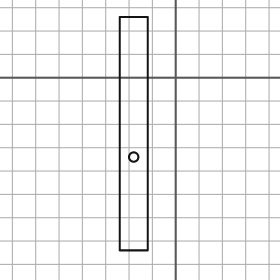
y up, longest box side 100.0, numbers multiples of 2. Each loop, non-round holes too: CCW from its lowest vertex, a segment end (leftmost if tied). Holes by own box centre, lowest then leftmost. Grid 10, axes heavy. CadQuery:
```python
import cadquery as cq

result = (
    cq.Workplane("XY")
    .moveTo(-24.0, -74.0)
    .lineTo(-12.0, -74.0)
    .lineTo(-12.0, 26.0)
    .lineTo(-24.0, 26.0)
    .close()
    .moveTo(-18.0, -34.0)
    .circle(2.0)
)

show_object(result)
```